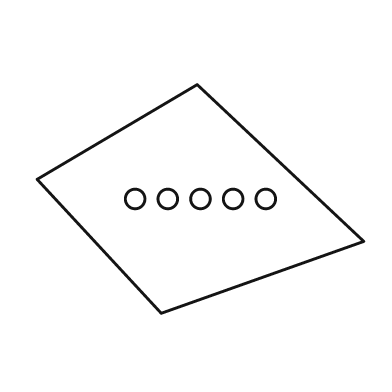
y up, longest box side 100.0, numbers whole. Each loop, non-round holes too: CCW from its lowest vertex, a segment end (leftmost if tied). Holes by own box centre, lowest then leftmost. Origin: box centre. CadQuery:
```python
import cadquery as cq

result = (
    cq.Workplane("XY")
    .moveTo(-12.0, -35.0)
    .lineTo(50.0, -13.0)
    .lineTo(-1.0, 35.0)
    .lineTo(-50.0, 6.0)
    .close()
    .moveTo(-20.0, 0.0)
    .circle(3.0)
    .moveTo(-10.0, 0.0)
    .circle(3.0)
    .moveTo(0.0, 0.0)
    .circle(3.0)
    .moveTo(10.0, 0.0)
    .circle(3.0)
    .moveTo(20.0, 0.0)
    .circle(3.0)
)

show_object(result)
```